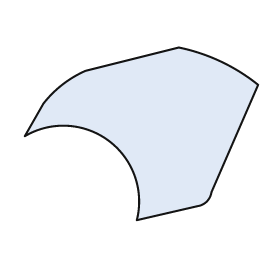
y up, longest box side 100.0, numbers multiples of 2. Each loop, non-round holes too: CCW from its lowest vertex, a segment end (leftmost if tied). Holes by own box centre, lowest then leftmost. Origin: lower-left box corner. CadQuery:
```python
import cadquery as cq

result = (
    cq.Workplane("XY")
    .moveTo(48.0, 0.0)
    .lineTo(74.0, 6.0)
    .threePointArc((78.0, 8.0), (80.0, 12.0))
    .lineTo(100.0, 58.0)
    .threePointArc((84.0, 68.0), (66.0, 74.0))
    .lineTo(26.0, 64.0)
    .threePointArc((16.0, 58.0), (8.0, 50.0))
    .lineTo(0.0, 36.0)
    .threePointArc((36.0, 34.0), (48.0, 0.0))
    .close()
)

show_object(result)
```